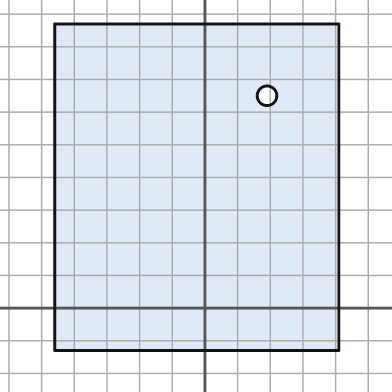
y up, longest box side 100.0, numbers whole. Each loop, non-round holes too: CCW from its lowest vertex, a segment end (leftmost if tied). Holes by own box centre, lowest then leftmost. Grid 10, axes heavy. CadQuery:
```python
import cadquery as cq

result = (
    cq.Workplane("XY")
    .moveTo(-46.0, -13.0)
    .lineTo(41.0, -13.0)
    .lineTo(41.0, 87.0)
    .lineTo(-46.0, 87.0)
    .close()
    .moveTo(19.0, 65.0)
    .circle(3.0)
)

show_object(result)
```